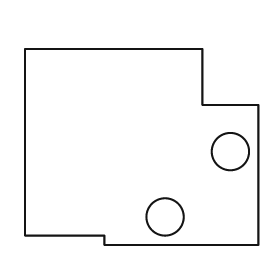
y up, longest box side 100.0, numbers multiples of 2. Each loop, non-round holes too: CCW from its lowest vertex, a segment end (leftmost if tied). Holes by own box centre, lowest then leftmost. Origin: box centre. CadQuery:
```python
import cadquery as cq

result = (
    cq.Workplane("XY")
    .moveTo(-16.0, -42.0)
    .lineTo(50.0, -42.0)
    .lineTo(50.0, 18.0)
    .lineTo(26.0, 18.0)
    .lineTo(26.0, 42.0)
    .lineTo(-50.0, 42.0)
    .lineTo(-50.0, -38.0)
    .lineTo(-16.0, -38.0)
    .close()
    .moveTo(10.0, -30.0)
    .circle(8.0)
    .moveTo(38.0, -2.0)
    .circle(8.0)
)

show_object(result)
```